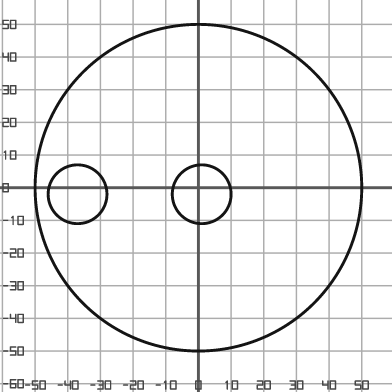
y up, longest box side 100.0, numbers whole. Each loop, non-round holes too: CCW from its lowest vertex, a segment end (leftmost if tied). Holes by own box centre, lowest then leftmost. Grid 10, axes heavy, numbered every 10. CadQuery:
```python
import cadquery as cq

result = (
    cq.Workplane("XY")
    .moveTo(0.0, 0.0)
    .circle(50.0)
    .moveTo(-37.0, -2.0)
    .circle(9.0)
    .moveTo(1.0, -2.0)
    .circle(9.0)
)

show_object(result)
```